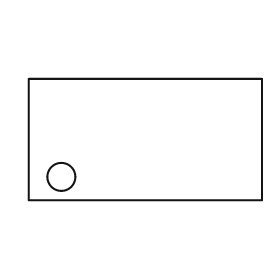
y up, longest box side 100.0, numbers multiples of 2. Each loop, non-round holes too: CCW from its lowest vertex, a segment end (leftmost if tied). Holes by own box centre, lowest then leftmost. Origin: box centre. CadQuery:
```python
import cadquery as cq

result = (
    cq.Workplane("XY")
    .moveTo(-50.0, -26.0)
    .lineTo(50.0, -26.0)
    .lineTo(50.0, 26.0)
    .lineTo(-50.0, 26.0)
    .close()
    .moveTo(-36.0, -16.0)
    .circle(6.0)
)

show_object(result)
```